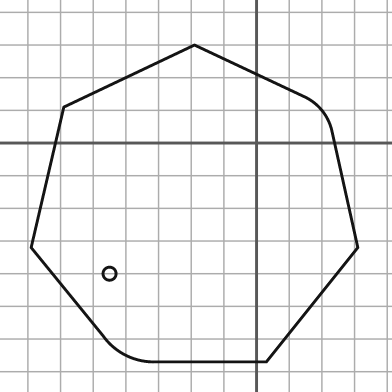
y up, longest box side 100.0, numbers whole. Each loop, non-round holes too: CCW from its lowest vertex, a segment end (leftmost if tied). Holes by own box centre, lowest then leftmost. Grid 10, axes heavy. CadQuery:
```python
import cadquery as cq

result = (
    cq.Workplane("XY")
    .moveTo(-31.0, -67.0)
    .lineTo(3.0, -67.0)
    .lineTo(31.0, -32.0)
    .lineTo(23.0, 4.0)
    .threePointArc((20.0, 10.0), (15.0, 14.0))
    .lineTo(-19.0, 30.0)
    .lineTo(-59.0, 11.0)
    .lineTo(-69.0, -32.0)
    .lineTo(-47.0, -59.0)
    .threePointArc((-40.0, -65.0), (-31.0, -67.0))
    .close()
    .moveTo(-45.0, -40.0)
    .circle(2.0)
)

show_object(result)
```